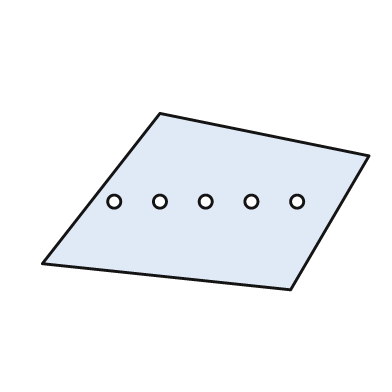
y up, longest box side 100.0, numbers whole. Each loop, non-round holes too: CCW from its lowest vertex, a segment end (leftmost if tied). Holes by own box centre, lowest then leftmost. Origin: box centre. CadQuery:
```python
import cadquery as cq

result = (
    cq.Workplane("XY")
    .moveTo(26.0, -27.0)
    .lineTo(50.0, 14.0)
    .lineTo(-14.0, 27.0)
    .lineTo(-50.0, -19.0)
    .close()
    .moveTo(-28.0, 0.0)
    .circle(2.0)
    .moveTo(-14.0, 0.0)
    .circle(2.0)
    .moveTo(0.0, 0.0)
    .circle(2.0)
    .moveTo(14.0, 0.0)
    .circle(2.0)
    .moveTo(28.0, 0.0)
    .circle(2.0)
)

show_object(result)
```